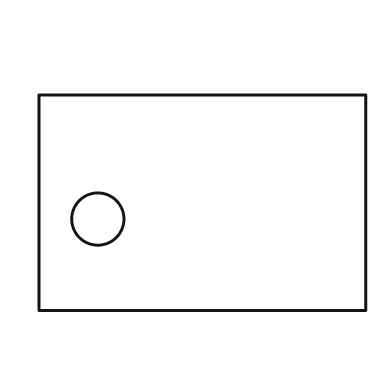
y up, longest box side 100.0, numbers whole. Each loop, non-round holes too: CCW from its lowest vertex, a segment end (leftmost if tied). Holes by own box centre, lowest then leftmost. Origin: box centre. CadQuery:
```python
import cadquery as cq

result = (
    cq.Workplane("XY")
    .moveTo(-50.0, -33.0)
    .lineTo(50.0, -33.0)
    .lineTo(50.0, 33.0)
    .lineTo(-50.0, 33.0)
    .close()
    .moveTo(-32.0, -5.0)
    .circle(8.0)
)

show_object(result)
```